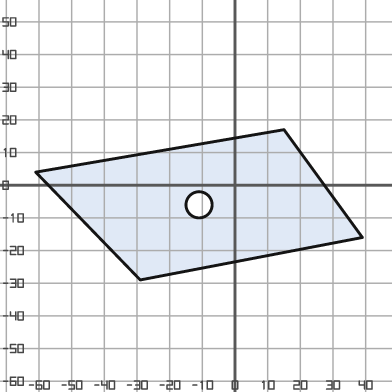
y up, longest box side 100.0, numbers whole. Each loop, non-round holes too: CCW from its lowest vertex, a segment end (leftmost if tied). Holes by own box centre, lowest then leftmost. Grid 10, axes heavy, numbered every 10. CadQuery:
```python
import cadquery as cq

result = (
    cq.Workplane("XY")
    .moveTo(-29.0, -29.0)
    .lineTo(39.0, -16.0)
    .lineTo(15.0, 17.0)
    .lineTo(-61.0, 4.0)
    .close()
    .moveTo(-11.0, -6.0)
    .circle(4.0)
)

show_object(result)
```